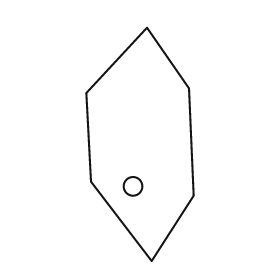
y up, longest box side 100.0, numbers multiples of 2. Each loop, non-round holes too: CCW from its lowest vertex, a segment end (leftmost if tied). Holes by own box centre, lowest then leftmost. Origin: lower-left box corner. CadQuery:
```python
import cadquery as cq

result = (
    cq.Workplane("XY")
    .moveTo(28.0, 0.0)
    .lineTo(46.0, 28.0)
    .lineTo(44.0, 74.0)
    .lineTo(26.0, 100.0)
    .lineTo(0.0, 72.0)
    .lineTo(2.0, 34.0)
    .close()
    .moveTo(20.0, 32.0)
    .circle(4.0)
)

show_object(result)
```